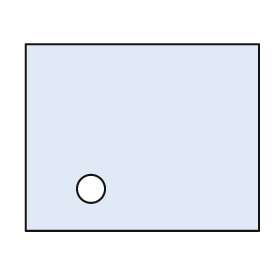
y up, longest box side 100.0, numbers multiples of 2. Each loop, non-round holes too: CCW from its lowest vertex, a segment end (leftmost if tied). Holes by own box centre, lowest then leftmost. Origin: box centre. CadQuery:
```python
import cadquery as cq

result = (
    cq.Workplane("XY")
    .moveTo(-50.0, -40.0)
    .lineTo(50.0, -40.0)
    .lineTo(50.0, 40.0)
    .lineTo(-50.0, 40.0)
    .close()
    .moveTo(-22.0, -22.0)
    .circle(6.0)
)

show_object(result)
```